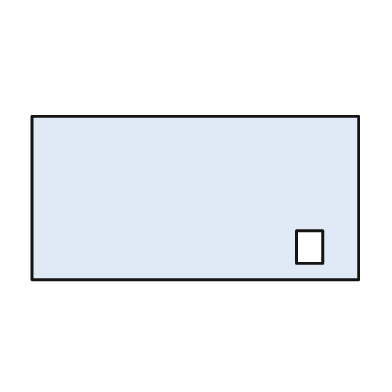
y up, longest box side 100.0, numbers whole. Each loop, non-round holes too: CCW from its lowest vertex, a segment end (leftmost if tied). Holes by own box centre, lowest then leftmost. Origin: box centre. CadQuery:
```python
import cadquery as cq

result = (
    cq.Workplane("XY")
    .moveTo(-50.0, -25.0)
    .lineTo(50.0, -25.0)
    .lineTo(50.0, 25.0)
    .lineTo(-50.0, 25.0)
    .close()
    .moveTo(31.0, -20.0)
    .lineTo(39.0, -20.0)
    .lineTo(39.0, -10.0)
    .lineTo(31.0, -10.0)
    .close()
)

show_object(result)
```